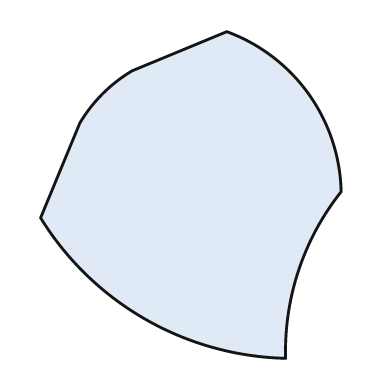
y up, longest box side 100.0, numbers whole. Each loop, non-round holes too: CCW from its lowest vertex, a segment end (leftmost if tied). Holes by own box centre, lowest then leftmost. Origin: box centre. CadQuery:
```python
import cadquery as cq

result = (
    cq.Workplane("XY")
    .moveTo(29.0, -50.0)
    .threePointArc((33.0, -23.0), (46.0, 1.0))
    .threePointArc((36.0, 31.0), (11.0, 50.0))
    .lineTo(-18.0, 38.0)
    .threePointArc((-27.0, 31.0), (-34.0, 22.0))
    .lineTo(-46.0, -7.0)
    .threePointArc((-14.0, -38.0), (29.0, -50.0))
    .close()
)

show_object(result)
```